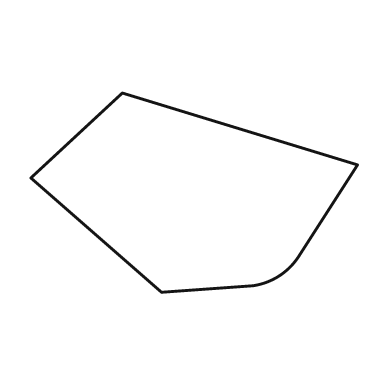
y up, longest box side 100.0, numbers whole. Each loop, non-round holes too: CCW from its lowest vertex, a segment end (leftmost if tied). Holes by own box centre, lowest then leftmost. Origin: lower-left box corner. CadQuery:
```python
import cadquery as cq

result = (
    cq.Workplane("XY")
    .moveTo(40.0, 0.0)
    .lineTo(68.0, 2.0)
    .threePointArc((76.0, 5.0), (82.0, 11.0))
    .lineTo(100.0, 39.0)
    .lineTo(28.0, 61.0)
    .lineTo(0.0, 35.0)
    .close()
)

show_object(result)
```